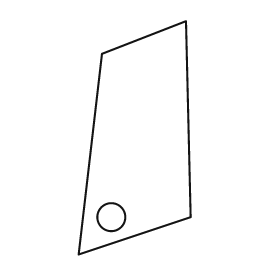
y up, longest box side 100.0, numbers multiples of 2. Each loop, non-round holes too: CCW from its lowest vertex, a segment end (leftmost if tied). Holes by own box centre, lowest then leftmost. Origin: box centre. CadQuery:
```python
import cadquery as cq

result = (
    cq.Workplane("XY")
    .moveTo(-24.0, -50.0)
    .lineTo(24.0, -34.0)
    .lineTo(22.0, 50.0)
    .lineTo(-14.0, 36.0)
    .close()
    .moveTo(-10.0, -34.0)
    .circle(6.0)
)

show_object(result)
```